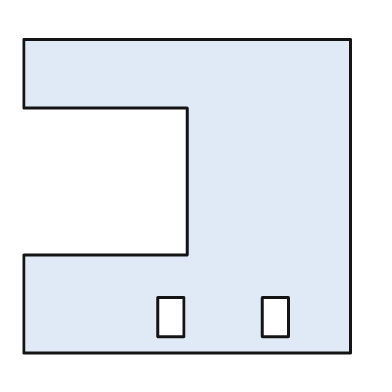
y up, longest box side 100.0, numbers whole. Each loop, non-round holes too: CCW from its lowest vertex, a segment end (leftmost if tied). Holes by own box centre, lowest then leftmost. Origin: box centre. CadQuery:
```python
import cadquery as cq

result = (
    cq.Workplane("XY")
    .moveTo(-50.0, -48.0)
    .lineTo(50.0, -48.0)
    .lineTo(50.0, 48.0)
    .lineTo(-50.0, 48.0)
    .lineTo(-50.0, 27.0)
    .lineTo(0.0, 27.0)
    .lineTo(0.0, -18.0)
    .lineTo(-50.0, -18.0)
    .close()
    .moveTo(-9.0, -43.0)
    .lineTo(-1.0, -43.0)
    .lineTo(-1.0, -31.0)
    .lineTo(-9.0, -31.0)
    .close()
    .moveTo(23.0, -43.0)
    .lineTo(31.0, -43.0)
    .lineTo(31.0, -31.0)
    .lineTo(23.0, -31.0)
    .close()
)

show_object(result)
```